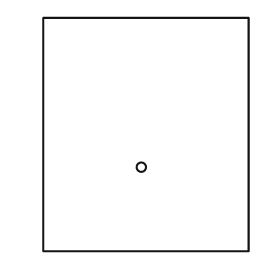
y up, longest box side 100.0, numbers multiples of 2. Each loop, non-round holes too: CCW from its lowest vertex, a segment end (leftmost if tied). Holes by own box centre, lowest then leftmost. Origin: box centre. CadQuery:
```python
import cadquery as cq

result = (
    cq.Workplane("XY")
    .moveTo(-44.0, -50.0)
    .lineTo(44.0, -50.0)
    .lineTo(44.0, 50.0)
    .lineTo(-44.0, 50.0)
    .close()
    .moveTo(-2.0, -14.0)
    .circle(2.0)
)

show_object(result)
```